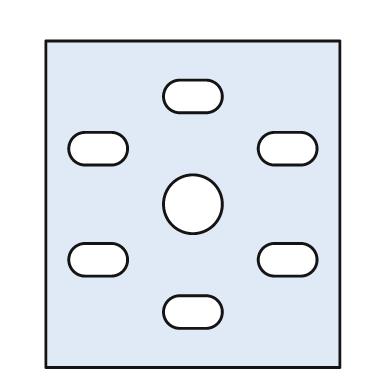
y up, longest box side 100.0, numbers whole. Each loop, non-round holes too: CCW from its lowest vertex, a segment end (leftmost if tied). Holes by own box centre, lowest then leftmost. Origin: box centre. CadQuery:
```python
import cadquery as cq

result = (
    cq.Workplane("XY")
    .moveTo(-45.0, -50.0)
    .lineTo(45.0, -50.0)
    .lineTo(45.0, 50.0)
    .lineTo(-45.0, 50.0)
    .close()
    .moveTo(-4.0, -38.0)
    .lineTo(4.0, -38.0)
    .threePointArc((9.0, -33.0), (4.0, -28.0))
    .lineTo(-4.0, -28.0)
    .threePointArc((-9.0, -33.0), (-4.0, -38.0))
    .close()
    .moveTo(-33.0, -22.0)
    .lineTo(-25.0, -22.0)
    .threePointArc((-20.0, -17.0), (-25.0, -12.0))
    .lineTo(-33.0, -12.0)
    .threePointArc((-38.0, -17.0), (-33.0, -22.0))
    .close()
    .moveTo(25.0, -22.0)
    .lineTo(33.0, -22.0)
    .threePointArc((38.0, -17.0), (33.0, -12.0))
    .lineTo(25.0, -12.0)
    .threePointArc((20.0, -17.0), (25.0, -22.0))
    .close()
    .moveTo(0.0, 0.0)
    .circle(9.0)
    .moveTo(-33.0, 12.0)
    .lineTo(-25.0, 12.0)
    .threePointArc((-20.0, 17.0), (-25.0, 22.0))
    .lineTo(-33.0, 22.0)
    .threePointArc((-38.0, 17.0), (-33.0, 12.0))
    .close()
    .moveTo(25.0, 12.0)
    .lineTo(33.0, 12.0)
    .threePointArc((38.0, 17.0), (33.0, 22.0))
    .lineTo(25.0, 22.0)
    .threePointArc((20.0, 17.0), (25.0, 12.0))
    .close()
    .moveTo(-4.0, 28.0)
    .lineTo(4.0, 28.0)
    .threePointArc((9.0, 33.0), (4.0, 38.0))
    .lineTo(-4.0, 38.0)
    .threePointArc((-9.0, 33.0), (-4.0, 28.0))
    .close()
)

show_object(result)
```